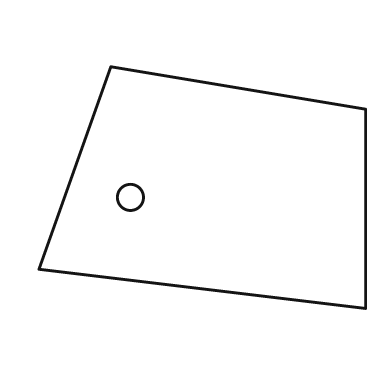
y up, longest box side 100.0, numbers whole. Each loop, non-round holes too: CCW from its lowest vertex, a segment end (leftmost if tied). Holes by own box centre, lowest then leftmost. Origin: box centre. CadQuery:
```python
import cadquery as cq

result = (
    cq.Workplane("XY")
    .moveTo(50.0, -37.0)
    .lineTo(50.0, 24.0)
    .lineTo(-28.0, 37.0)
    .lineTo(-50.0, -25.0)
    .close()
    .moveTo(-22.0, -3.0)
    .circle(4.0)
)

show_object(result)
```